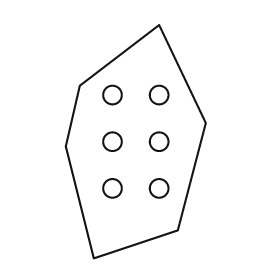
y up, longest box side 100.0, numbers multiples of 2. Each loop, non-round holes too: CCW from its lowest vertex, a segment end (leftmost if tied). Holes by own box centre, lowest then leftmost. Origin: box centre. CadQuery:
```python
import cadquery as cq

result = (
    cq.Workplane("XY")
    .moveTo(-18.0, -50.0)
    .lineTo(18.0, -38.0)
    .lineTo(30.0, 8.0)
    .lineTo(10.0, 50.0)
    .lineTo(-24.0, 24.0)
    .lineTo(-30.0, -2.0)
    .close()
    .moveTo(-10.0, -20.0)
    .circle(4.0)
    .moveTo(10.0, -20.0)
    .circle(4.0)
    .moveTo(-10.0, 0.0)
    .circle(4.0)
    .moveTo(10.0, 0.0)
    .circle(4.0)
    .moveTo(-10.0, 20.0)
    .circle(4.0)
    .moveTo(10.0, 20.0)
    .circle(4.0)
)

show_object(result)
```